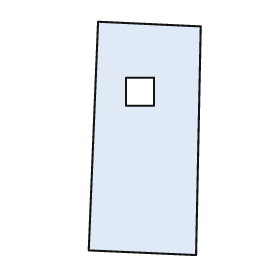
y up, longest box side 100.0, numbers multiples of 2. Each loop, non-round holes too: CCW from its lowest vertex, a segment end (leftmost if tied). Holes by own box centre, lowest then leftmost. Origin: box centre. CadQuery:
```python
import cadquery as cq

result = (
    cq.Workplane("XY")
    .moveTo(22.0, -50.0)
    .lineTo(24.0, 48.0)
    .lineTo(-20.0, 50.0)
    .lineTo(-24.0, -48.0)
    .close()
    .moveTo(-8.0, 14.0)
    .lineTo(4.0, 14.0)
    .lineTo(4.0, 26.0)
    .lineTo(-8.0, 26.0)
    .close()
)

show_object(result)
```